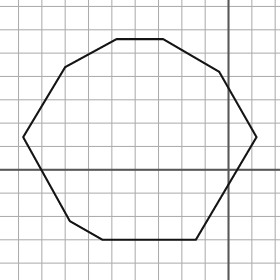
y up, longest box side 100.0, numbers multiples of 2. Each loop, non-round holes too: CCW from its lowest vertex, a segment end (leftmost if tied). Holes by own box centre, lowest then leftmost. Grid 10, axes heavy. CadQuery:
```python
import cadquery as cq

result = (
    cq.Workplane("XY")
    .moveTo(-54.0, -30.0)
    .lineTo(-14.0, -30.0)
    .lineTo(12.0, 14.0)
    .lineTo(-4.0, 42.0)
    .lineTo(-28.0, 56.0)
    .lineTo(-48.0, 56.0)
    .lineTo(-70.0, 44.0)
    .lineTo(-88.0, 14.0)
    .lineTo(-68.0, -22.0)
    .close()
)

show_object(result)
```